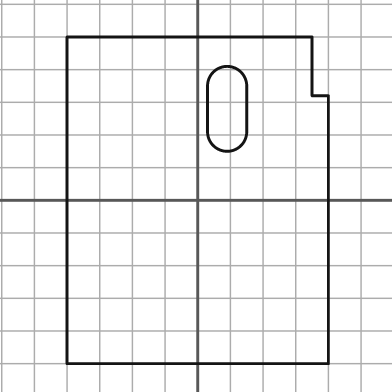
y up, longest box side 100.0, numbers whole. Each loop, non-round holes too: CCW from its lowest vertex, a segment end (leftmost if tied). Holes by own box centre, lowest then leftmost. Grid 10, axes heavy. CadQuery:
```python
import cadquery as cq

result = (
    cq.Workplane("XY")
    .moveTo(-40.0, -50.0)
    .lineTo(40.0, -50.0)
    .lineTo(40.0, 32.0)
    .lineTo(35.0, 32.0)
    .lineTo(35.0, 50.0)
    .lineTo(-40.0, 50.0)
    .close()
    .moveTo(3.0, 21.0)
    .threePointArc((9.0, 15.0), (15.0, 21.0))
    .lineTo(15.0, 35.0)
    .threePointArc((9.0, 41.0), (3.0, 35.0))
    .close()
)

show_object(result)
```